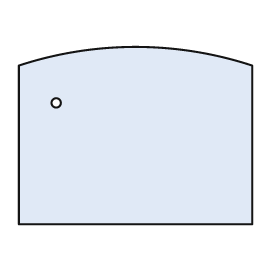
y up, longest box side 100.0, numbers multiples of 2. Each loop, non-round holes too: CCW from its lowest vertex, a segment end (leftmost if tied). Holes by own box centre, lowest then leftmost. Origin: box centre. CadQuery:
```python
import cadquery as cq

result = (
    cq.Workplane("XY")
    .moveTo(-50.0, -38.0)
    .lineTo(50.0, -38.0)
    .lineTo(50.0, 30.0)
    .threePointArc((0.0, 38.0), (-50.0, 30.0))
    .close()
    .moveTo(-34.0, 14.0)
    .circle(2.0)
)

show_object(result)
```